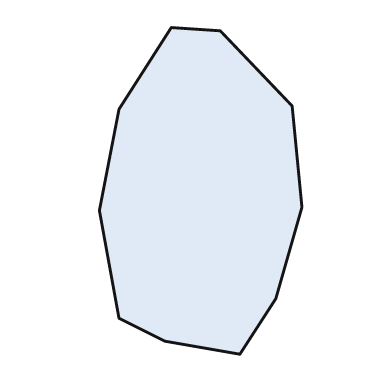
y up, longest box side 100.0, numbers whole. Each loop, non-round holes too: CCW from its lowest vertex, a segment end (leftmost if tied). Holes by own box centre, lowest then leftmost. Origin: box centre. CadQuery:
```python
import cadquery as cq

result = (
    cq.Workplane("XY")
    .moveTo(12.0, -50.0)
    .lineTo(23.0, -33.0)
    .lineTo(31.0, -5.0)
    .lineTo(28.0, 26.0)
    .lineTo(6.0, 49.0)
    .lineTo(-9.0, 50.0)
    .lineTo(-25.0, 25.0)
    .lineTo(-31.0, -6.0)
    .lineTo(-25.0, -39.0)
    .lineTo(-11.0, -46.0)
    .close()
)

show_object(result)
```